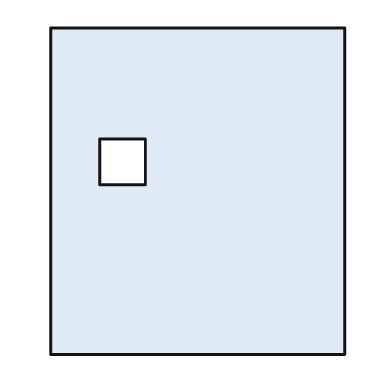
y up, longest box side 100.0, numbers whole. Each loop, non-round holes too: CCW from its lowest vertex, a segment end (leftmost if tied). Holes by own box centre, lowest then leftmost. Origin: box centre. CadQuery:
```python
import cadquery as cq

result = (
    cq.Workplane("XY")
    .moveTo(-45.0, -50.0)
    .lineTo(45.0, -50.0)
    .lineTo(45.0, 50.0)
    .lineTo(-45.0, 50.0)
    .close()
    .moveTo(-30.0, 2.0)
    .lineTo(-16.0, 2.0)
    .lineTo(-16.0, 16.0)
    .lineTo(-30.0, 16.0)
    .close()
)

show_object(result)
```